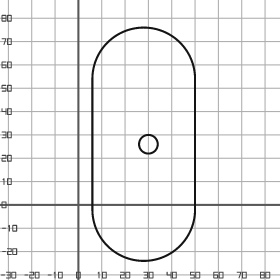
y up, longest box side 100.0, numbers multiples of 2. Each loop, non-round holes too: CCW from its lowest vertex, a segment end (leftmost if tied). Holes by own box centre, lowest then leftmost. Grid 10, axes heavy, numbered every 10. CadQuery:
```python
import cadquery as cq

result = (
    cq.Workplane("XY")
    .moveTo(6.0, -2.0)
    .threePointArc((28.0, -24.0), (50.0, -2.0))
    .lineTo(50.0, 54.0)
    .threePointArc((28.0, 76.0), (6.0, 54.0))
    .close()
    .moveTo(30.0, 26.0)
    .circle(4.0)
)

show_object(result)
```